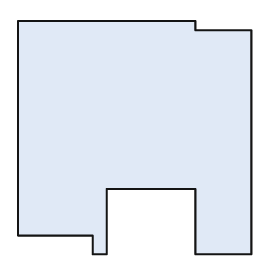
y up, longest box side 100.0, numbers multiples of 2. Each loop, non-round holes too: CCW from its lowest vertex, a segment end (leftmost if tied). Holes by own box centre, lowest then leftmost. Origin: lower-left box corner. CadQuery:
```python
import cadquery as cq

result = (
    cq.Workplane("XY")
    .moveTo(32.0, 0.0)
    .lineTo(38.0, 0.0)
    .lineTo(38.0, 28.0)
    .lineTo(76.0, 28.0)
    .lineTo(76.0, 0.0)
    .lineTo(100.0, 0.0)
    .lineTo(100.0, 96.0)
    .lineTo(76.0, 96.0)
    .lineTo(76.0, 100.0)
    .lineTo(0.0, 100.0)
    .lineTo(0.0, 8.0)
    .lineTo(32.0, 8.0)
    .close()
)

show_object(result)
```